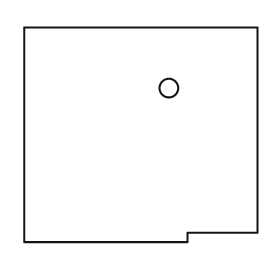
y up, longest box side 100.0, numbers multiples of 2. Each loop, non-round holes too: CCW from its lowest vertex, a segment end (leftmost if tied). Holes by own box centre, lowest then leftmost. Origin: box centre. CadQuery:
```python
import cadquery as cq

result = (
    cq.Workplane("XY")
    .moveTo(-50.0, -46.0)
    .lineTo(20.0, -46.0)
    .lineTo(20.0, -42.0)
    .lineTo(50.0, -42.0)
    .lineTo(50.0, 46.0)
    .lineTo(-50.0, 46.0)
    .close()
    .moveTo(12.0, 20.0)
    .circle(4.0)
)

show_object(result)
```